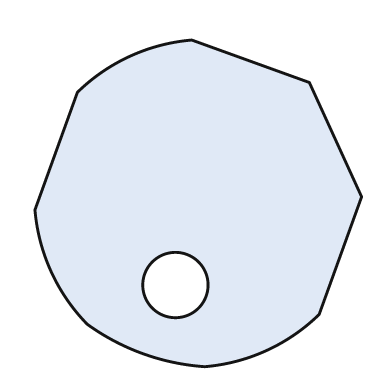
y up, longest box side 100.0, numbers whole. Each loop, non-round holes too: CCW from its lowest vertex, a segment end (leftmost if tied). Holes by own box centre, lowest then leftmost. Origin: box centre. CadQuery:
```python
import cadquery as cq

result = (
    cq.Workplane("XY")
    .moveTo(2.0, -50.0)
    .threePointArc((21.0, -45.0), (37.0, -34.0))
    .lineTo(50.0, 2.0)
    .lineTo(34.0, 37.0)
    .lineTo(-2.0, 50.0)
    .threePointArc((-21.0, 45.0), (-37.0, 34.0))
    .lineTo(-50.0, -2.0)
    .threePointArc((-45.0, -21.0), (-34.0, -37.0))
    .threePointArc((-17.0, -46.0), (2.0, -50.0))
    .close()
    .moveTo(-7.0, -25.0)
    .circle(10.0)
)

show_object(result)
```